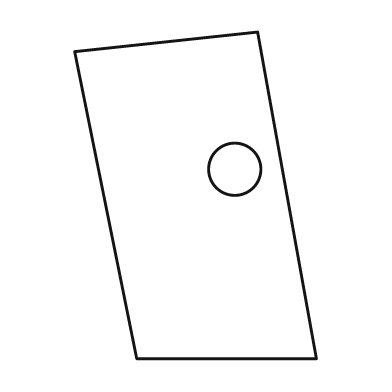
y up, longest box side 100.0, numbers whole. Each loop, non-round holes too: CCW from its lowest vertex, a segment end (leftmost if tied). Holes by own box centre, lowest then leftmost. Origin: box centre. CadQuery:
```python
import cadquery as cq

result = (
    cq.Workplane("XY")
    .moveTo(-18.0, -50.0)
    .lineTo(37.0, -50.0)
    .lineTo(19.0, 50.0)
    .lineTo(-37.0, 44.0)
    .close()
    .moveTo(12.0, 8.0)
    .circle(8.0)
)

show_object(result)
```